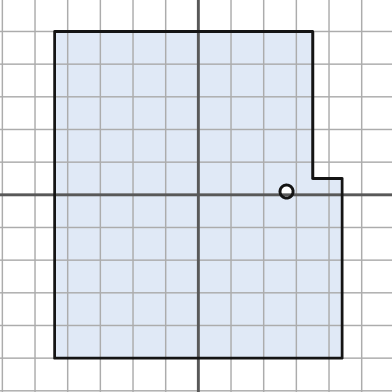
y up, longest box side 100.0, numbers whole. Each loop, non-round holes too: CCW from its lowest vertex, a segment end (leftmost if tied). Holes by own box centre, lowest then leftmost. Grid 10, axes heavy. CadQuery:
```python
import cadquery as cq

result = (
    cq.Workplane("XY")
    .moveTo(-44.0, -50.0)
    .lineTo(44.0, -50.0)
    .lineTo(44.0, 5.0)
    .lineTo(35.0, 5.0)
    .lineTo(35.0, 50.0)
    .lineTo(-44.0, 50.0)
    .close()
    .moveTo(27.0, 1.0)
    .circle(2.0)
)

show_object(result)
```